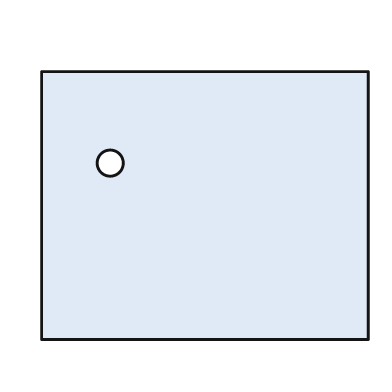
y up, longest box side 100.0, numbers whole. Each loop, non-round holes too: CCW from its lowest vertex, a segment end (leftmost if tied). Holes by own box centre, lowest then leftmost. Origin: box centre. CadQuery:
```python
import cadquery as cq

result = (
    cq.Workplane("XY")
    .moveTo(-50.0, -41.0)
    .lineTo(50.0, -41.0)
    .lineTo(50.0, 41.0)
    .lineTo(-50.0, 41.0)
    .close()
    .moveTo(-29.0, 13.0)
    .circle(4.0)
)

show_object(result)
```